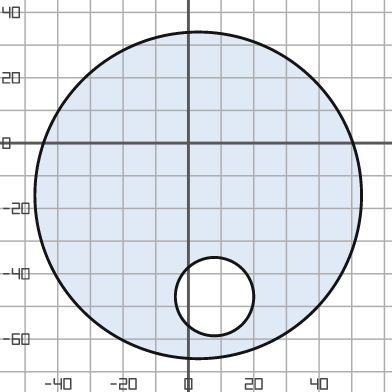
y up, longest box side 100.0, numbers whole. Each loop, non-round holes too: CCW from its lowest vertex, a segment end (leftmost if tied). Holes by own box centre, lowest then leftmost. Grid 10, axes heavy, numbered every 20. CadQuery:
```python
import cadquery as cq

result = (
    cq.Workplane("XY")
    .moveTo(3.0, -16.0)
    .circle(50.0)
    .moveTo(8.0, -47.0)
    .circle(12.0)
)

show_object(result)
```